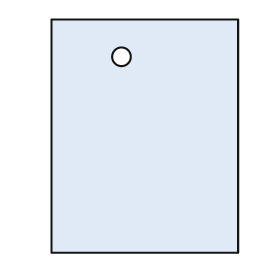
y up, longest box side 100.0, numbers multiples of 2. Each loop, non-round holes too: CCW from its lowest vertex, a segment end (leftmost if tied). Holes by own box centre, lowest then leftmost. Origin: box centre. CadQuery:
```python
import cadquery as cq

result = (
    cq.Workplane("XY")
    .moveTo(-40.0, -50.0)
    .lineTo(40.0, -50.0)
    .lineTo(40.0, 50.0)
    .lineTo(-40.0, 50.0)
    .close()
    .moveTo(-10.0, 34.0)
    .circle(4.0)
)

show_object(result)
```